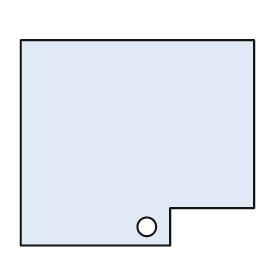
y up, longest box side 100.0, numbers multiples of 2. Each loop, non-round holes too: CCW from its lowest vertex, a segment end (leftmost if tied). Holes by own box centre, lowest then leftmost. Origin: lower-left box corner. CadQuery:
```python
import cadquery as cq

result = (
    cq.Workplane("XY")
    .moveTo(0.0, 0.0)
    .lineTo(64.0, 0.0)
    .lineTo(64.0, 16.0)
    .lineTo(100.0, 16.0)
    .lineTo(100.0, 88.0)
    .lineTo(0.0, 88.0)
    .close()
    .moveTo(54.0, 8.0)
    .circle(4.0)
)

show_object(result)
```